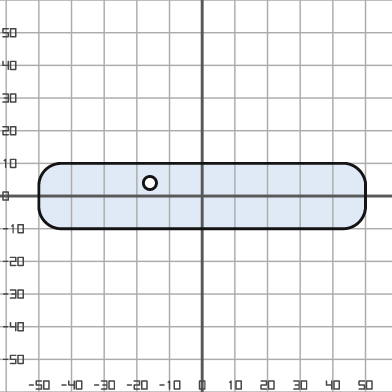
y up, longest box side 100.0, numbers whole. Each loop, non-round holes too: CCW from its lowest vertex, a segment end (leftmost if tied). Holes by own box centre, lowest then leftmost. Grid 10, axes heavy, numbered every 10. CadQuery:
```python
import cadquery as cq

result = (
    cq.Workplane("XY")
    .moveTo(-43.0, -10.0)
    .lineTo(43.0, -10.0)
    .threePointArc((48.0, -8.0), (50.0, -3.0))
    .lineTo(50.0, 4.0)
    .threePointArc((48.0, 8.0), (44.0, 10.0))
    .lineTo(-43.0, 10.0)
    .threePointArc((-48.0, 8.0), (-50.0, 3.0))
    .lineTo(-50.0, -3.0)
    .threePointArc((-48.0, -8.0), (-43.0, -10.0))
    .close()
    .moveTo(-16.0, 4.0)
    .circle(2.0)
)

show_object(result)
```